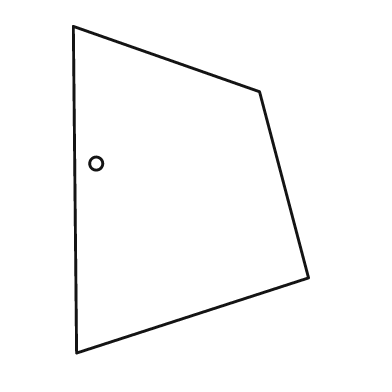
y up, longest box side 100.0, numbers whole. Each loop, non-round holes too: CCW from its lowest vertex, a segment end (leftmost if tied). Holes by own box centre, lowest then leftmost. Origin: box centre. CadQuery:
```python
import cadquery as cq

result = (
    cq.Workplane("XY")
    .moveTo(-35.0, -50.0)
    .lineTo(36.0, -27.0)
    .lineTo(21.0, 30.0)
    .lineTo(-36.0, 50.0)
    .close()
    .moveTo(-29.0, 8.0)
    .circle(2.0)
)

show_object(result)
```